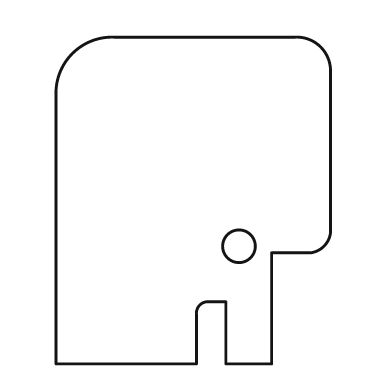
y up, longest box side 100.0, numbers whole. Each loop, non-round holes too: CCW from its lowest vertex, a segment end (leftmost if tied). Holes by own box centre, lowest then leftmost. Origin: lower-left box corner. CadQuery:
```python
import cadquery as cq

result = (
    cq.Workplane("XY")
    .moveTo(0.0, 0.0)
    .lineTo(43.0, 0.0)
    .lineTo(43.0, 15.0)
    .threePointArc((44.0, 18.0), (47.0, 19.0))
    .lineTo(52.0, 19.0)
    .lineTo(52.0, 0.0)
    .lineTo(66.0, 0.0)
    .lineTo(66.0, 34.0)
    .lineTo(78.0, 34.0)
    .threePointArc((82.0, 36.0), (84.0, 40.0))
    .lineTo(84.0, 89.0)
    .threePointArc((81.0, 97.0), (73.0, 100.0))
    .lineTo(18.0, 100.0)
    .threePointArc((5.0, 95.0), (0.0, 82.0))
    .close()
    .moveTo(56.0, 36.0)
    .circle(5.0)
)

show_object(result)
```